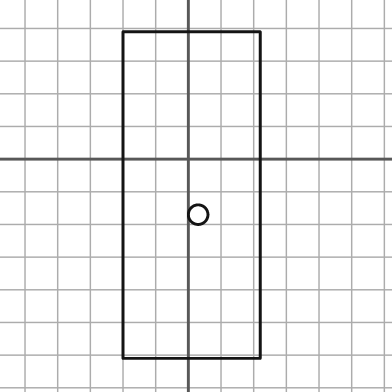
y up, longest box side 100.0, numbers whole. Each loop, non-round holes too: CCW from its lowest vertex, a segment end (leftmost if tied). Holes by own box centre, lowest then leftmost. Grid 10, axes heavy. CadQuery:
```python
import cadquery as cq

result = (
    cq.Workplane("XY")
    .moveTo(-20.0, -61.0)
    .lineTo(22.0, -61.0)
    .lineTo(22.0, 39.0)
    .lineTo(-20.0, 39.0)
    .close()
    .moveTo(3.0, -17.0)
    .circle(3.0)
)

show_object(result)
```